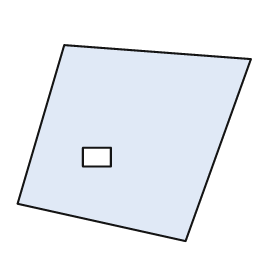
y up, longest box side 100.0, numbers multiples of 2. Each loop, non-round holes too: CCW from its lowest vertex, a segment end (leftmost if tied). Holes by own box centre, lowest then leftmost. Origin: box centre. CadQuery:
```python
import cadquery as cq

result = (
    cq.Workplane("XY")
    .moveTo(22.0, -42.0)
    .lineTo(50.0, 36.0)
    .lineTo(-30.0, 42.0)
    .lineTo(-50.0, -26.0)
    .close()
    .moveTo(-22.0, -10.0)
    .lineTo(-10.0, -10.0)
    .lineTo(-10.0, -2.0)
    .lineTo(-22.0, -2.0)
    .close()
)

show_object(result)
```